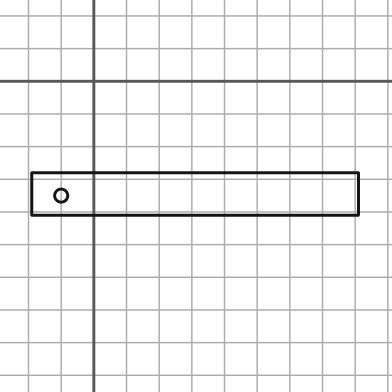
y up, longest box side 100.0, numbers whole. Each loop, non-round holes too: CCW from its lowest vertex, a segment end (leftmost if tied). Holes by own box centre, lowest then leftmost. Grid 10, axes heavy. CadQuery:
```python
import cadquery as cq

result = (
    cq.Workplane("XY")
    .moveTo(-19.0, -41.0)
    .lineTo(81.0, -41.0)
    .lineTo(81.0, -28.0)
    .lineTo(-19.0, -28.0)
    .close()
    .moveTo(-10.0, -35.0)
    .circle(2.0)
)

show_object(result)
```